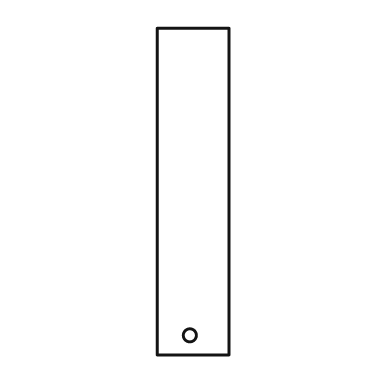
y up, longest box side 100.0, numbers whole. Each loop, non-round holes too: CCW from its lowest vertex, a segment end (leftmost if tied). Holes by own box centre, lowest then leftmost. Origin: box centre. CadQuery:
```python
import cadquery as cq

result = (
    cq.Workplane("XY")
    .moveTo(-11.0, -50.0)
    .lineTo(11.0, -50.0)
    .lineTo(11.0, 50.0)
    .lineTo(-11.0, 50.0)
    .close()
    .moveTo(-1.0, -44.0)
    .circle(2.0)
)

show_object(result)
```